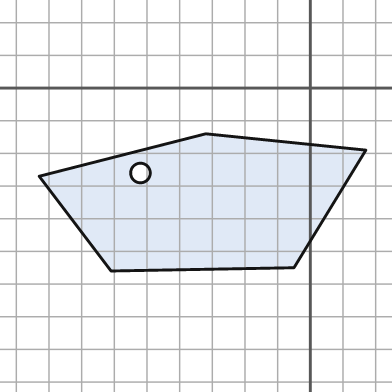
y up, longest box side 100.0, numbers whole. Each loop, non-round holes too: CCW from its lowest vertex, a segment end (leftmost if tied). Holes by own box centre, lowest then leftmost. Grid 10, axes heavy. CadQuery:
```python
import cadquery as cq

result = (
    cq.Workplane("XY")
    .moveTo(-61.0, -56.0)
    .lineTo(-5.0, -55.0)
    .lineTo(17.0, -19.0)
    .lineTo(-32.0, -14.0)
    .lineTo(-83.0, -27.0)
    .close()
    .moveTo(-52.0, -26.0)
    .circle(3.0)
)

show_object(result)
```